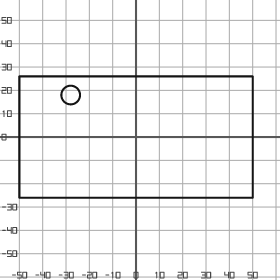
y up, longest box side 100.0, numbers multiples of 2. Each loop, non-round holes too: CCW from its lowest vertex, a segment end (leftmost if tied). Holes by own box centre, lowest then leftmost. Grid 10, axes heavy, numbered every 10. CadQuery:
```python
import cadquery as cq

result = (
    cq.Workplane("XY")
    .moveTo(-50.0, -26.0)
    .lineTo(50.0, -26.0)
    .lineTo(50.0, 26.0)
    .lineTo(-50.0, 26.0)
    .close()
    .moveTo(-28.0, 18.0)
    .circle(4.0)
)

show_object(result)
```